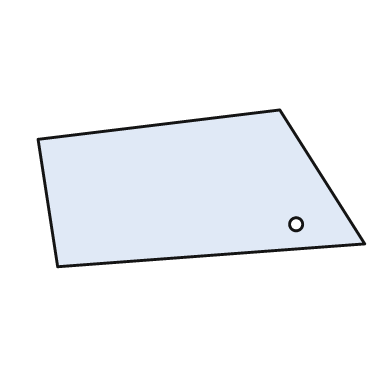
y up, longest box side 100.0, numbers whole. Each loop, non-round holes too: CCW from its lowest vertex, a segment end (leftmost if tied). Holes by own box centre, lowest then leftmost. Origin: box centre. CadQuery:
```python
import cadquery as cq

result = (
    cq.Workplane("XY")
    .moveTo(-44.0, -24.0)
    .lineTo(50.0, -17.0)
    .lineTo(24.0, 24.0)
    .lineTo(-50.0, 15.0)
    .close()
    .moveTo(29.0, -11.0)
    .circle(2.0)
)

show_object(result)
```